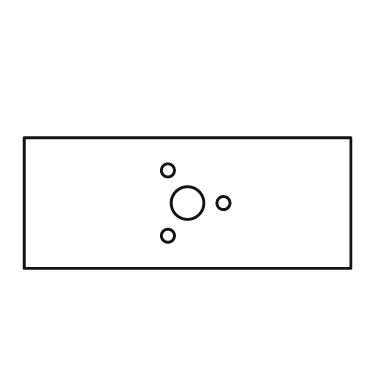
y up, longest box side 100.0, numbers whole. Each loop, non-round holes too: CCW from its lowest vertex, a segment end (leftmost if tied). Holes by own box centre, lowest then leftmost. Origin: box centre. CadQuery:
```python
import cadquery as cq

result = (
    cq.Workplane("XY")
    .moveTo(-50.0, -20.0)
    .lineTo(50.0, -20.0)
    .lineTo(50.0, 20.0)
    .lineTo(-50.0, 20.0)
    .close()
    .moveTo(-6.0, -10.0)
    .circle(2.0)
    .moveTo(0.0, 0.0)
    .circle(5.0)
    .moveTo(11.0, 0.0)
    .circle(2.0)
    .moveTo(-6.0, 10.0)
    .circle(2.0)
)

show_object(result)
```